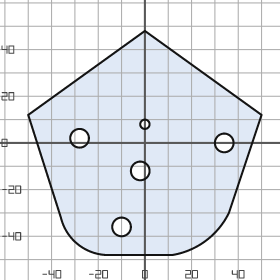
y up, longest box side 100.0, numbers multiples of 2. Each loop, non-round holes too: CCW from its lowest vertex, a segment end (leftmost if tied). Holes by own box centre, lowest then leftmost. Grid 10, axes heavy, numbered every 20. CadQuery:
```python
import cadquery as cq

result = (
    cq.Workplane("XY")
    .moveTo(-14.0, -48.0)
    .lineTo(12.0, -48.0)
    .threePointArc((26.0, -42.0), (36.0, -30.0))
    .lineTo(50.0, 12.0)
    .lineTo(0.0, 48.0)
    .lineTo(-50.0, 12.0)
    .lineTo(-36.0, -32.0)
    .threePointArc((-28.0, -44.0), (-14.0, -48.0))
    .close()
    .moveTo(-10.0, -36.0)
    .circle(4.0)
    .moveTo(-2.0, -12.0)
    .circle(4.0)
    .moveTo(34.0, 0.0)
    .circle(4.0)
    .moveTo(-28.0, 2.0)
    .circle(4.0)
    .moveTo(0.0, 8.0)
    .circle(2.0)
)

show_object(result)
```